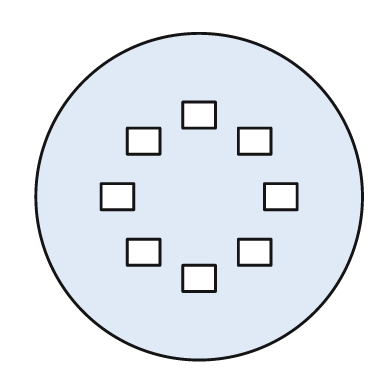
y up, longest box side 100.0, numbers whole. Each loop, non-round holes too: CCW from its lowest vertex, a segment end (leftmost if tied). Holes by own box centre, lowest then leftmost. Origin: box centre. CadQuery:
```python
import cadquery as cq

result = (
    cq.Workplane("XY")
    .moveTo(0.0, 0.0)
    .circle(50.0)
    .moveTo(-5.0, -29.0)
    .lineTo(5.0, -29.0)
    .lineTo(5.0, -21.0)
    .lineTo(-5.0, -21.0)
    .close()
    .moveTo(-22.0, -21.0)
    .lineTo(-12.0, -21.0)
    .lineTo(-12.0, -13.0)
    .lineTo(-22.0, -13.0)
    .close()
    .moveTo(12.0, -21.0)
    .lineTo(22.0, -21.0)
    .lineTo(22.0, -13.0)
    .lineTo(12.0, -13.0)
    .close()
    .moveTo(-30.0, -4.0)
    .lineTo(-20.0, -4.0)
    .lineTo(-20.0, 4.0)
    .lineTo(-30.0, 4.0)
    .close()
    .moveTo(20.0, -4.0)
    .lineTo(30.0, -4.0)
    .lineTo(30.0, 4.0)
    .lineTo(20.0, 4.0)
    .close()
    .moveTo(-22.0, 13.0)
    .lineTo(-12.0, 13.0)
    .lineTo(-12.0, 21.0)
    .lineTo(-22.0, 21.0)
    .close()
    .moveTo(12.0, 13.0)
    .lineTo(22.0, 13.0)
    .lineTo(22.0, 21.0)
    .lineTo(12.0, 21.0)
    .close()
    .moveTo(-5.0, 21.0)
    .lineTo(5.0, 21.0)
    .lineTo(5.0, 29.0)
    .lineTo(-5.0, 29.0)
    .close()
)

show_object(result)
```